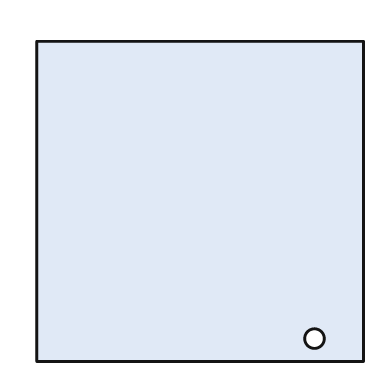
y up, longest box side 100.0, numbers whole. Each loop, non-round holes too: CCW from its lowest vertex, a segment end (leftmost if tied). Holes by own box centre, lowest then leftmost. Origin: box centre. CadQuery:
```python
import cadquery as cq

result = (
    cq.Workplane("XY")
    .moveTo(-50.0, -49.0)
    .lineTo(50.0, -49.0)
    .lineTo(50.0, 49.0)
    .lineTo(-50.0, 49.0)
    .close()
    .moveTo(35.0, -42.0)
    .circle(3.0)
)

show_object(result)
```